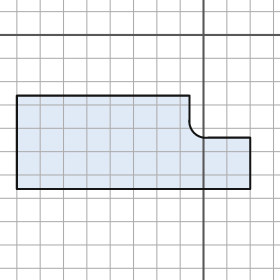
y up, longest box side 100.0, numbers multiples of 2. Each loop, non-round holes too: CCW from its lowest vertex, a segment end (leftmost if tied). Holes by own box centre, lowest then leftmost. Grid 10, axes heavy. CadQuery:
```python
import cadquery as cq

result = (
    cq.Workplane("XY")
    .moveTo(-80.0, -66.0)
    .lineTo(20.0, -66.0)
    .lineTo(20.0, -44.0)
    .lineTo(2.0, -44.0)
    .threePointArc((-4.0, -42.0), (-6.0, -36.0))
    .lineTo(-6.0, -26.0)
    .lineTo(-80.0, -26.0)
    .close()
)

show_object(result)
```